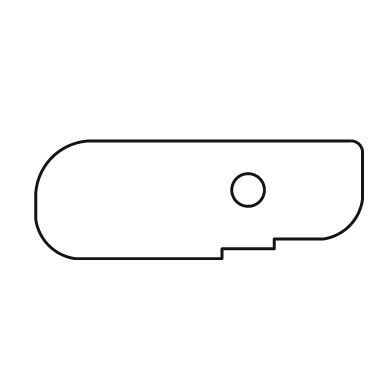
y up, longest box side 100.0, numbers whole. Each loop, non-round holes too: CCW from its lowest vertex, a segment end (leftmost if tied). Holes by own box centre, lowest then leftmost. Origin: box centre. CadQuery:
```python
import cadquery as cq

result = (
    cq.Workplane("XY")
    .moveTo(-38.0, -18.0)
    .lineTo(7.0, -18.0)
    .lineTo(7.0, -15.0)
    .lineTo(23.0, -15.0)
    .lineTo(23.0, -12.0)
    .lineTo(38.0, -12.0)
    .threePointArc((46.0, -8.0), (50.0, 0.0))
    .lineTo(50.0, 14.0)
    .threePointArc((49.0, 17.0), (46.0, 18.0))
    .lineTo(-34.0, 18.0)
    .threePointArc((-45.0, 13.0), (-50.0, 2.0))
    .lineTo(-50.0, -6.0)
    .threePointArc((-46.0, -14.0), (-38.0, -18.0))
    .close()
    .moveTo(15.0, 3.0)
    .circle(5.0)
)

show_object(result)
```